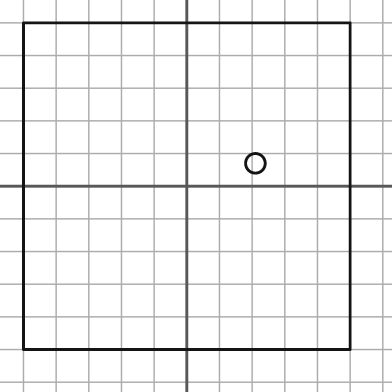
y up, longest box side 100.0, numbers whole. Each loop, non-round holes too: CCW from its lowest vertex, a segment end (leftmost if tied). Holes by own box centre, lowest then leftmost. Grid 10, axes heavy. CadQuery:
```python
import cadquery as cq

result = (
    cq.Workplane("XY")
    .moveTo(-50.0, -50.0)
    .lineTo(50.0, -50.0)
    .lineTo(50.0, 50.0)
    .lineTo(-50.0, 50.0)
    .close()
    .moveTo(21.0, 7.0)
    .circle(3.0)
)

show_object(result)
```